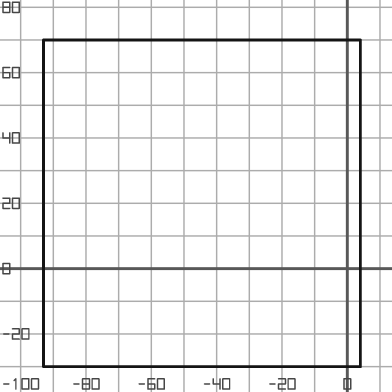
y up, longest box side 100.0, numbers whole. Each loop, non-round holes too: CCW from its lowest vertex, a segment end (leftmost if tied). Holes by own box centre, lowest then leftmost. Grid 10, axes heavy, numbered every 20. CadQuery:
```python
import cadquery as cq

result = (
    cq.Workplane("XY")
    .moveTo(-93.0, -30.0)
    .lineTo(4.0, -30.0)
    .lineTo(4.0, 70.0)
    .lineTo(-93.0, 70.0)
    .close()
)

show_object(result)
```